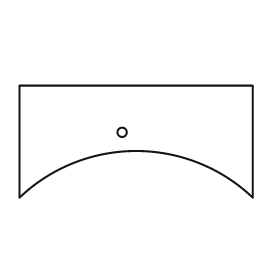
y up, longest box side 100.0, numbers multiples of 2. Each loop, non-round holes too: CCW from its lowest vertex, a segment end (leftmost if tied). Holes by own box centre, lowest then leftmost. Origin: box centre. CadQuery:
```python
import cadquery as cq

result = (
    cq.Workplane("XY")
    .moveTo(-50.0, -24.0)
    .threePointArc((0.0, -4.0), (50.0, -24.0))
    .lineTo(50.0, 24.0)
    .lineTo(-50.0, 24.0)
    .close()
    .moveTo(-6.0, 4.0)
    .circle(2.0)
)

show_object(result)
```